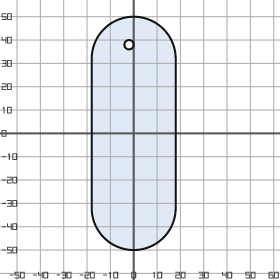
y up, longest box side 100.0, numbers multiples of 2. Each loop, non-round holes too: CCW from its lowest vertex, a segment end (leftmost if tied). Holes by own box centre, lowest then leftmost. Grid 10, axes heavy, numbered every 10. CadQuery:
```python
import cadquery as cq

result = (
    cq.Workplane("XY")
    .moveTo(-18.0, -32.0)
    .threePointArc((0.0, -50.0), (18.0, -32.0))
    .lineTo(18.0, 32.0)
    .threePointArc((0.0, 50.0), (-18.0, 32.0))
    .close()
    .moveTo(-2.0, 38.0)
    .circle(2.0)
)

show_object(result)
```